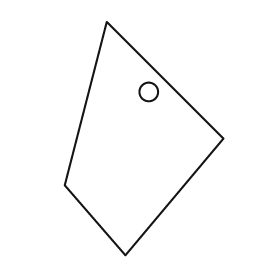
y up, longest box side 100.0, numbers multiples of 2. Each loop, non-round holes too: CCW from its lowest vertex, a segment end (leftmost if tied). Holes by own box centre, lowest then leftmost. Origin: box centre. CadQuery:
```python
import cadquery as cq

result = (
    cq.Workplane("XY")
    .moveTo(-8.0, -50.0)
    .lineTo(34.0, 0.0)
    .lineTo(-16.0, 50.0)
    .lineTo(-34.0, -20.0)
    .close()
    .moveTo(2.0, 20.0)
    .circle(4.0)
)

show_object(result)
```